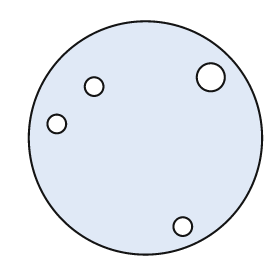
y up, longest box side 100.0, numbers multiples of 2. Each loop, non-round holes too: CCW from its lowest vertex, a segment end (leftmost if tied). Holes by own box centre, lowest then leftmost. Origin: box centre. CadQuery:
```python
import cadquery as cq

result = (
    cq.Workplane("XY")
    .moveTo(0.0, 0.0)
    .circle(50.0)
    .moveTo(16.0, -38.0)
    .circle(4.0)
    .moveTo(-38.0, 6.0)
    .circle(4.0)
    .moveTo(-22.0, 22.0)
    .circle(4.0)
    .moveTo(28.0, 26.0)
    .circle(6.0)
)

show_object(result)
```